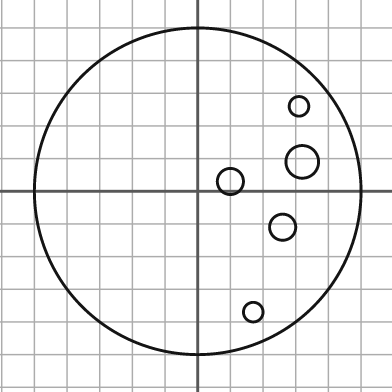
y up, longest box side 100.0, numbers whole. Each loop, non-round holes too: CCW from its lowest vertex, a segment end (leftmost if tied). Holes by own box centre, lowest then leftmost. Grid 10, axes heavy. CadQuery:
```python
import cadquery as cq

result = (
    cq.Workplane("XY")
    .moveTo(0.0, 0.0)
    .circle(50.0)
    .moveTo(17.0, -37.0)
    .circle(3.0)
    .moveTo(26.0, -11.0)
    .circle(4.0)
    .moveTo(10.0, 3.0)
    .circle(4.0)
    .moveTo(32.0, 9.0)
    .circle(5.0)
    .moveTo(31.0, 26.0)
    .circle(3.0)
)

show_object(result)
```